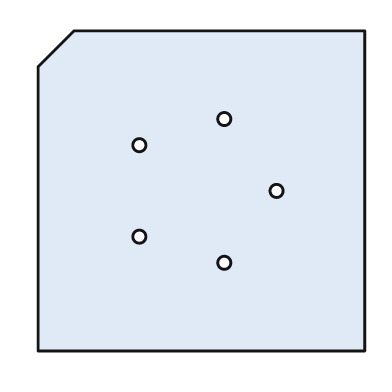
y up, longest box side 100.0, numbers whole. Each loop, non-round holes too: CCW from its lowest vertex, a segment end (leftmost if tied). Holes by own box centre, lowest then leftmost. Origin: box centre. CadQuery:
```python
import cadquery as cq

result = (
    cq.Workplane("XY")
    .moveTo(-50.0, -49.0)
    .lineTo(50.0, -49.0)
    .lineTo(50.0, 49.0)
    .lineTo(-39.0, 49.0)
    .lineTo(-50.0, 38.0)
    .close()
    .moveTo(7.0, -22.0)
    .circle(2.0)
    .moveTo(-19.0, -14.0)
    .circle(2.0)
    .moveTo(23.0, 0.0)
    .circle(2.0)
    .moveTo(-19.0, 14.0)
    .circle(2.0)
    .moveTo(7.0, 22.0)
    .circle(2.0)
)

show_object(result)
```